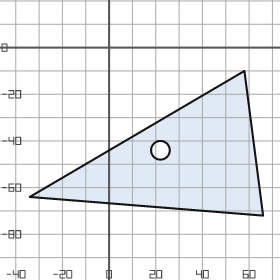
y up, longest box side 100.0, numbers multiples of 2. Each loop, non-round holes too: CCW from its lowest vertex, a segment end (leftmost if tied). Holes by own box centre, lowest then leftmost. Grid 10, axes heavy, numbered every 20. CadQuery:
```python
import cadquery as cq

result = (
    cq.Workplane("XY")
    .moveTo(66.0, -72.0)
    .lineTo(58.0, -10.0)
    .lineTo(-34.0, -64.0)
    .close()
    .moveTo(22.0, -44.0)
    .circle(4.0)
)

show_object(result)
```